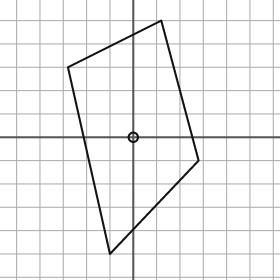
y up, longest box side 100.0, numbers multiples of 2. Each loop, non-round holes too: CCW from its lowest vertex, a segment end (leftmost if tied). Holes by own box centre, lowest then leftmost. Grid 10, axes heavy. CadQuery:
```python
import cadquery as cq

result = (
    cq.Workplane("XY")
    .moveTo(-10.0, -50.0)
    .lineTo(28.0, -10.0)
    .lineTo(12.0, 50.0)
    .lineTo(-28.0, 30.0)
    .close()
    .moveTo(0.0, 0.0)
    .circle(2.0)
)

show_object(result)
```